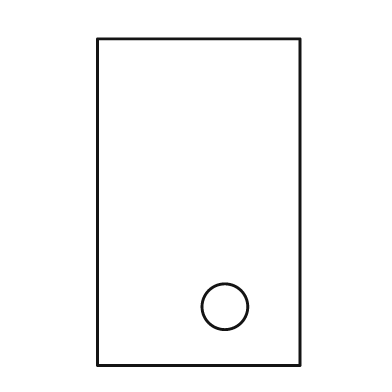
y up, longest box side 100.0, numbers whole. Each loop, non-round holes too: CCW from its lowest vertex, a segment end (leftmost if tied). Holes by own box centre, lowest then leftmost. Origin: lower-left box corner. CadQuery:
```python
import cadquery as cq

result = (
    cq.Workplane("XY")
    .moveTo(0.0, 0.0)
    .lineTo(62.0, 0.0)
    .lineTo(62.0, 100.0)
    .lineTo(0.0, 100.0)
    .close()
    .moveTo(39.0, 18.0)
    .circle(7.0)
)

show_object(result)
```